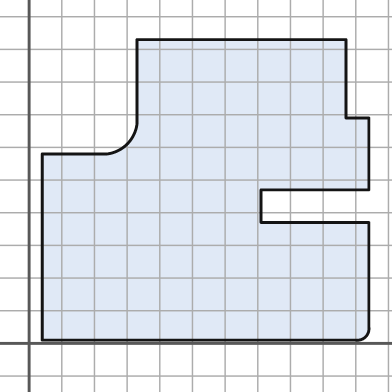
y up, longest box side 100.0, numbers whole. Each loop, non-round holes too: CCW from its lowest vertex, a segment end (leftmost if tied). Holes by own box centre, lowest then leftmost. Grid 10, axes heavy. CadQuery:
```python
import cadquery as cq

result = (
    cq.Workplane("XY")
    .moveTo(4.0, 1.0)
    .lineTo(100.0, 1.0)
    .threePointArc((103.0, 2.0), (104.0, 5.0))
    .lineTo(104.0, 37.0)
    .lineTo(71.0, 37.0)
    .lineTo(71.0, 47.0)
    .lineTo(104.0, 47.0)
    .lineTo(104.0, 69.0)
    .lineTo(97.0, 69.0)
    .lineTo(97.0, 93.0)
    .lineTo(33.0, 93.0)
    .lineTo(33.0, 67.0)
    .threePointArc((30.0, 61.0), (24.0, 58.0))
    .lineTo(4.0, 58.0)
    .close()
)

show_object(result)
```